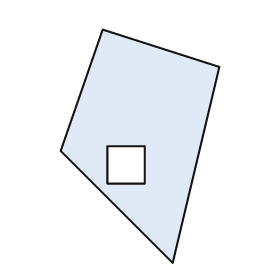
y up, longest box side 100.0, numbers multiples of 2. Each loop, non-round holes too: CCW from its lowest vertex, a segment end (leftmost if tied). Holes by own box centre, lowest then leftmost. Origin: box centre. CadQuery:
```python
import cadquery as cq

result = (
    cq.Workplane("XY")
    .moveTo(14.0, -50.0)
    .lineTo(34.0, 34.0)
    .lineTo(-16.0, 50.0)
    .lineTo(-34.0, -2.0)
    .close()
    .moveTo(-14.0, -16.0)
    .lineTo(2.0, -16.0)
    .lineTo(2.0, 0.0)
    .lineTo(-14.0, 0.0)
    .close()
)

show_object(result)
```